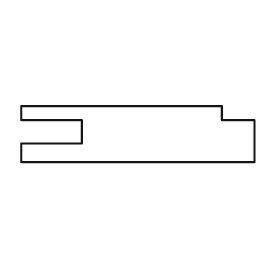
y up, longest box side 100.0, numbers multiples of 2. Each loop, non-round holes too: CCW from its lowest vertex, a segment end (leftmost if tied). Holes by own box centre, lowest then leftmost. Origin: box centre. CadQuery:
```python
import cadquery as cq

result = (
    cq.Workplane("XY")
    .moveTo(-50.0, -12.0)
    .lineTo(50.0, -12.0)
    .lineTo(50.0, 6.0)
    .lineTo(36.0, 6.0)
    .lineTo(36.0, 12.0)
    .lineTo(-50.0, 12.0)
    .lineTo(-50.0, 6.0)
    .lineTo(-24.0, 6.0)
    .lineTo(-24.0, -4.0)
    .lineTo(-50.0, -4.0)
    .close()
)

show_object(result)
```